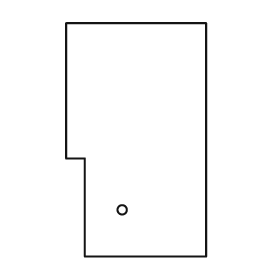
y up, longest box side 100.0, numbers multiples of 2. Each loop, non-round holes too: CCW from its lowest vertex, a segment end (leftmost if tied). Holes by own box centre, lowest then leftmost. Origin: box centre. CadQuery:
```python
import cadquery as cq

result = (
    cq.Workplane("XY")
    .moveTo(-22.0, -50.0)
    .lineTo(30.0, -50.0)
    .lineTo(30.0, 50.0)
    .lineTo(-30.0, 50.0)
    .lineTo(-30.0, -8.0)
    .lineTo(-22.0, -8.0)
    .close()
    .moveTo(-6.0, -30.0)
    .circle(2.0)
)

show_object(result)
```